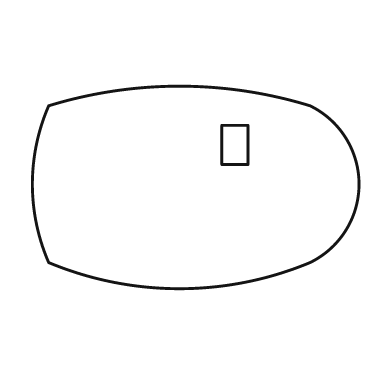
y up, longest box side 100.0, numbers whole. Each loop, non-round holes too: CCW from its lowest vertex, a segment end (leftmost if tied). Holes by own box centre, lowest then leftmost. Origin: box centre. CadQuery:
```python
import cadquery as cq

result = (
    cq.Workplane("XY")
    .moveTo(-45.0, -23.0)
    .threePointArc((-5.0, -31.0), (35.0, -23.0))
    .threePointArc((50.0, 1.0), (35.0, 25.0))
    .threePointArc((-5.0, 31.0), (-45.0, 25.0))
    .threePointArc((-50.0, 1.0), (-45.0, -23.0))
    .close()
    .moveTo(8.0, 7.0)
    .lineTo(16.0, 7.0)
    .lineTo(16.0, 19.0)
    .lineTo(8.0, 19.0)
    .close()
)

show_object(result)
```